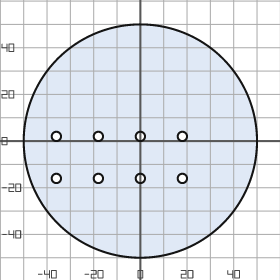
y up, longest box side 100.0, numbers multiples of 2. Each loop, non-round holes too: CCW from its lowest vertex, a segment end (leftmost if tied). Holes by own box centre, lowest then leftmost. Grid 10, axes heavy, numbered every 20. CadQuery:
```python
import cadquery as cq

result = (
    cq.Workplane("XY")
    .moveTo(0.0, 0.0)
    .circle(50.0)
    .moveTo(-36.0, -16.0)
    .circle(2.0)
    .moveTo(-18.0, -16.0)
    .circle(2.0)
    .moveTo(0.0, -16.0)
    .circle(2.0)
    .moveTo(18.0, -16.0)
    .circle(2.0)
    .moveTo(-36.0, 2.0)
    .circle(2.0)
    .moveTo(-18.0, 2.0)
    .circle(2.0)
    .moveTo(0.0, 2.0)
    .circle(2.0)
    .moveTo(18.0, 2.0)
    .circle(2.0)
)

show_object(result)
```